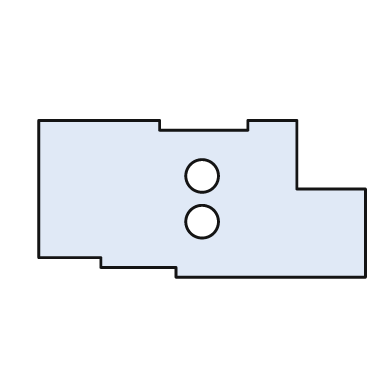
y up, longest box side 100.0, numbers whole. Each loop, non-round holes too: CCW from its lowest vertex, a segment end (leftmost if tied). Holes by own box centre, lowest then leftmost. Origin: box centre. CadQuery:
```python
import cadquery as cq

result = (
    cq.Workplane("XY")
    .moveTo(-8.0, -24.0)
    .lineTo(50.0, -24.0)
    .lineTo(50.0, 3.0)
    .lineTo(29.0, 3.0)
    .lineTo(29.0, 24.0)
    .lineTo(14.0, 24.0)
    .lineTo(14.0, 21.0)
    .lineTo(-13.0, 21.0)
    .lineTo(-13.0, 24.0)
    .lineTo(-50.0, 24.0)
    .lineTo(-50.0, -18.0)
    .lineTo(-31.0, -18.0)
    .lineTo(-31.0, -21.0)
    .lineTo(-8.0, -21.0)
    .close()
    .moveTo(0.0, -7.0)
    .circle(5.0)
    .moveTo(0.0, 7.0)
    .circle(5.0)
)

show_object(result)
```